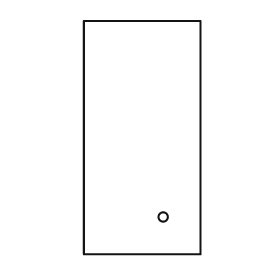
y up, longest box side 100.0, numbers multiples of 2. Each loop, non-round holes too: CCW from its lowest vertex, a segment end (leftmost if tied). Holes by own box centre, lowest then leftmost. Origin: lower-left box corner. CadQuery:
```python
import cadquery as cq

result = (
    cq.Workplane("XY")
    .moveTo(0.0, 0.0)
    .lineTo(50.0, 0.0)
    .lineTo(50.0, 100.0)
    .lineTo(0.0, 100.0)
    .close()
    .moveTo(34.0, 16.0)
    .circle(2.0)
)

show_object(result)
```